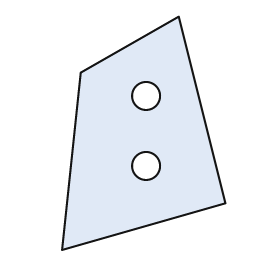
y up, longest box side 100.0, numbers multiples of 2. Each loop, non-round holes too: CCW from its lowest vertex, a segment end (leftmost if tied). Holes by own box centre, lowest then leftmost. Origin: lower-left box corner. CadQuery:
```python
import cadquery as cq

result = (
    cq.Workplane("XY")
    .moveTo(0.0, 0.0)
    .lineTo(70.0, 20.0)
    .lineTo(50.0, 100.0)
    .lineTo(8.0, 76.0)
    .close()
    .moveTo(36.0, 36.0)
    .circle(6.0)
    .moveTo(36.0, 66.0)
    .circle(6.0)
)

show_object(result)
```